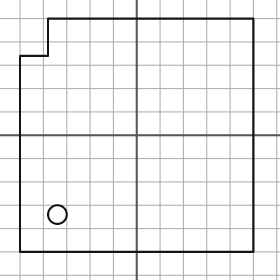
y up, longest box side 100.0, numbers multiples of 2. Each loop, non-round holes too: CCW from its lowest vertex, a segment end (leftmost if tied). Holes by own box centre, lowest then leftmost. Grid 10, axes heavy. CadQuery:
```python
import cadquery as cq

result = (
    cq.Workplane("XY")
    .moveTo(-50.0, -50.0)
    .lineTo(50.0, -50.0)
    .lineTo(50.0, 50.0)
    .lineTo(-38.0, 50.0)
    .lineTo(-38.0, 34.0)
    .lineTo(-50.0, 34.0)
    .close()
    .moveTo(-34.0, -34.0)
    .circle(4.0)
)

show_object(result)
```